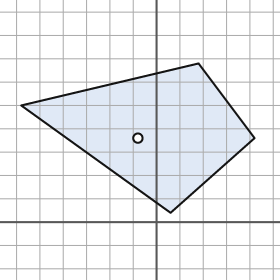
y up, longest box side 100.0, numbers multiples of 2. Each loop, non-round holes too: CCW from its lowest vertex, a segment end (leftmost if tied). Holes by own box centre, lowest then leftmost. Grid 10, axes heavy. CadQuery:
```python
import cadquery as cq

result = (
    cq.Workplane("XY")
    .moveTo(6.0, 4.0)
    .lineTo(42.0, 36.0)
    .lineTo(18.0, 68.0)
    .lineTo(-58.0, 50.0)
    .close()
    .moveTo(-8.0, 36.0)
    .circle(2.0)
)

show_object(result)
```